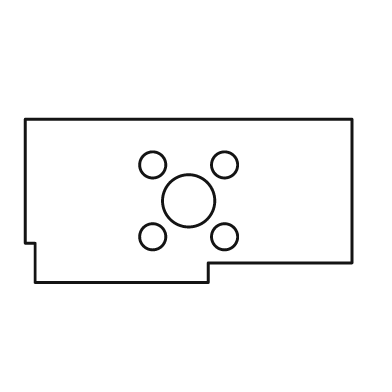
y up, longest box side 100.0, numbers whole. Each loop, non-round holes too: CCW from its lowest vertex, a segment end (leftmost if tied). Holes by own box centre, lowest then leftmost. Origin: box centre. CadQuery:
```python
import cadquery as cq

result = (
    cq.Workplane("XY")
    .moveTo(-47.0, -25.0)
    .lineTo(6.0, -25.0)
    .lineTo(6.0, -19.0)
    .lineTo(50.0, -19.0)
    .lineTo(50.0, 25.0)
    .lineTo(-50.0, 25.0)
    .lineTo(-50.0, -13.0)
    .lineTo(-47.0, -13.0)
    .close()
    .moveTo(-11.0, -11.0)
    .circle(4.0)
    .moveTo(11.0, -11.0)
    .circle(4.0)
    .moveTo(0.0, 0.0)
    .circle(8.0)
    .moveTo(-11.0, 11.0)
    .circle(4.0)
    .moveTo(11.0, 11.0)
    .circle(4.0)
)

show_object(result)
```